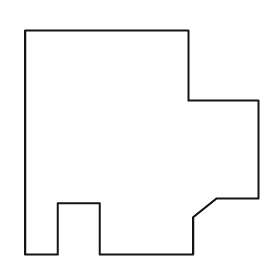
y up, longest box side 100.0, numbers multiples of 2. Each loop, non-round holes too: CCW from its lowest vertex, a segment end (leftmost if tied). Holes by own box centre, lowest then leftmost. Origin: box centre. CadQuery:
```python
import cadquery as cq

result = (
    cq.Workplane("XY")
    .moveTo(-50.0, -48.0)
    .lineTo(-36.0, -48.0)
    .lineTo(-36.0, -26.0)
    .lineTo(-18.0, -26.0)
    .lineTo(-18.0, -48.0)
    .lineTo(22.0, -48.0)
    .lineTo(22.0, -32.0)
    .lineTo(32.0, -24.0)
    .lineTo(50.0, -24.0)
    .lineTo(50.0, 18.0)
    .lineTo(20.0, 18.0)
    .lineTo(20.0, 48.0)
    .lineTo(-50.0, 48.0)
    .close()
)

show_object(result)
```